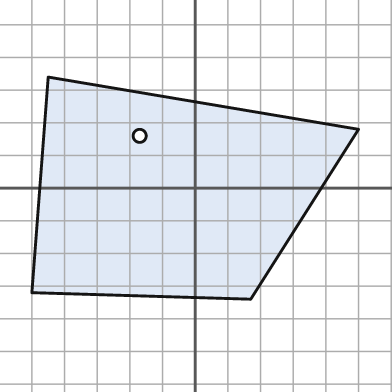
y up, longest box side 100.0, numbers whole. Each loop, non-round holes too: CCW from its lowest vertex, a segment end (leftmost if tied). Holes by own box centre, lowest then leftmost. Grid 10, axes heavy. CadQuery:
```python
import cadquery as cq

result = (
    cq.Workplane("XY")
    .moveTo(17.0, -34.0)
    .lineTo(50.0, 18.0)
    .lineTo(-45.0, 34.0)
    .lineTo(-50.0, -32.0)
    .close()
    .moveTo(-17.0, 16.0)
    .circle(2.0)
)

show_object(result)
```